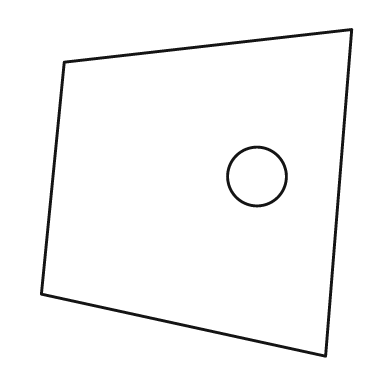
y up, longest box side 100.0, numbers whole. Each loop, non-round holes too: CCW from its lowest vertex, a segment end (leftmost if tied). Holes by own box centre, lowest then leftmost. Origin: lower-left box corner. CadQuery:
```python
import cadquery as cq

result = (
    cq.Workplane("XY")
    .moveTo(87.0, 0.0)
    .lineTo(95.0, 100.0)
    .lineTo(7.0, 90.0)
    .lineTo(0.0, 19.0)
    .close()
    .moveTo(66.0, 55.0)
    .circle(9.0)
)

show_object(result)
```